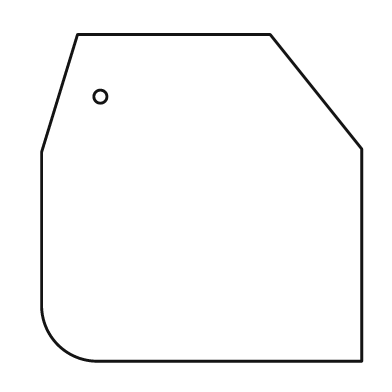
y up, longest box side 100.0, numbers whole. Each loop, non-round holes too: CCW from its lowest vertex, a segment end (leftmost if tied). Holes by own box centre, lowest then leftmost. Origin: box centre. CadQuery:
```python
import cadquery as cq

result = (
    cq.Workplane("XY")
    .moveTo(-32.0, -50.0)
    .lineTo(49.0, -50.0)
    .lineTo(49.0, 15.0)
    .lineTo(21.0, 50.0)
    .lineTo(-38.0, 50.0)
    .lineTo(-49.0, 14.0)
    .lineTo(-49.0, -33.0)
    .threePointArc((-44.0, -45.0), (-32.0, -50.0))
    .close()
    .moveTo(-31.0, 31.0)
    .circle(2.0)
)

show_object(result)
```